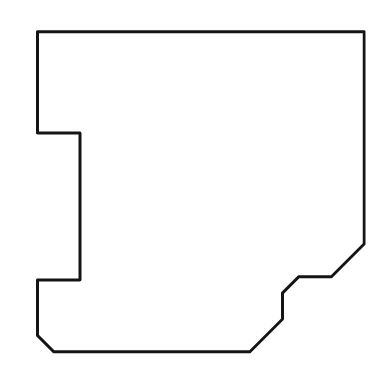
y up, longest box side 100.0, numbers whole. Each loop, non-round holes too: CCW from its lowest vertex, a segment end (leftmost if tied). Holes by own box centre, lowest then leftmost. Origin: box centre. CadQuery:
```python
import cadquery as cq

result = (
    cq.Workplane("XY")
    .moveTo(-45.0, -49.0)
    .lineTo(15.0, -49.0)
    .lineTo(25.0, -39.0)
    .lineTo(25.0, -31.0)
    .lineTo(30.0, -26.0)
    .lineTo(40.0, -26.0)
    .lineTo(50.0, -16.0)
    .lineTo(50.0, 49.0)
    .lineTo(-50.0, 49.0)
    .lineTo(-50.0, 18.0)
    .lineTo(-37.0, 18.0)
    .lineTo(-37.0, -27.0)
    .lineTo(-50.0, -27.0)
    .lineTo(-50.0, -44.0)
    .close()
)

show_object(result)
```